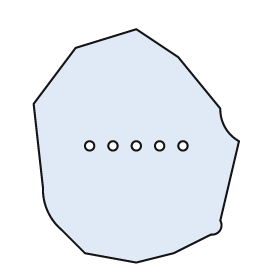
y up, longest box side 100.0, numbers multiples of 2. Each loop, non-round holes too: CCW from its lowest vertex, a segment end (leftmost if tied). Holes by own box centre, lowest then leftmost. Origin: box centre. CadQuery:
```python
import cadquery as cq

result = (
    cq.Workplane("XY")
    .moveTo(0.0, -50.0)
    .lineTo(16.0, -46.0)
    .lineTo(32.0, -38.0)
    .threePointArc((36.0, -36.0), (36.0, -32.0))
    .lineTo(44.0, 2.0)
    .threePointArc((38.0, 8.0), (36.0, 16.0))
    .lineTo(18.0, 38.0)
    .lineTo(0.0, 50.0)
    .lineTo(-26.0, 42.0)
    .lineTo(-44.0, 18.0)
    .lineTo(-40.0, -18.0)
    .threePointArc((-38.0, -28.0), (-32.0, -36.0))
    .lineTo(-22.0, -46.0)
    .close()
    .moveTo(-20.0, 0.0)
    .circle(2.0)
    .moveTo(-10.0, 0.0)
    .circle(2.0)
    .moveTo(0.0, 0.0)
    .circle(2.0)
    .moveTo(10.0, 0.0)
    .circle(2.0)
    .moveTo(20.0, 0.0)
    .circle(2.0)
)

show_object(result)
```